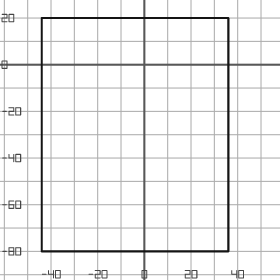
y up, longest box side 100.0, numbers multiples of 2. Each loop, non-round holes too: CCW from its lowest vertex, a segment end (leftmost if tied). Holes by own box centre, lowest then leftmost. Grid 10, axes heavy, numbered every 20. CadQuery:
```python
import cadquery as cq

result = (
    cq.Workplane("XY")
    .moveTo(-44.0, -80.0)
    .lineTo(36.0, -80.0)
    .lineTo(36.0, 20.0)
    .lineTo(-44.0, 20.0)
    .close()
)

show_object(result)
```